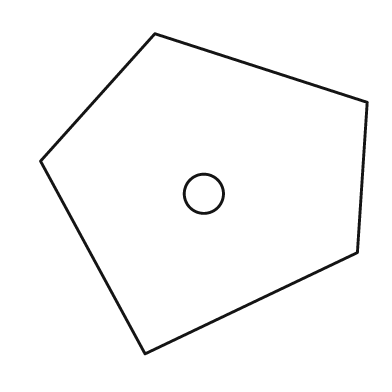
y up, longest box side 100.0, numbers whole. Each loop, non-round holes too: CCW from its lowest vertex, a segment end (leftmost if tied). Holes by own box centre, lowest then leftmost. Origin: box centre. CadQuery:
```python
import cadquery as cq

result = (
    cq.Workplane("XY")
    .moveTo(-18.0, -49.0)
    .lineTo(47.0, -18.0)
    .lineTo(50.0, 28.0)
    .lineTo(-15.0, 49.0)
    .lineTo(-50.0, 10.0)
    .close()
    .moveTo(0.0, 0.0)
    .circle(6.0)
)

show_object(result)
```